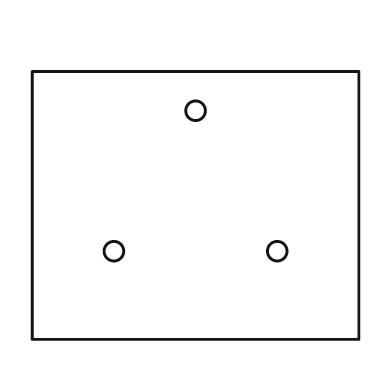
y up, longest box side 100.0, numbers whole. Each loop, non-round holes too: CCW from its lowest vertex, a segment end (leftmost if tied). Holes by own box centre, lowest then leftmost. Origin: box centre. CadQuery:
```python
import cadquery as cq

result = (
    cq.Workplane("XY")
    .moveTo(-50.0, -41.0)
    .lineTo(50.0, -41.0)
    .lineTo(50.0, 41.0)
    .lineTo(-50.0, 41.0)
    .close()
    .moveTo(-25.0, -14.0)
    .circle(3.0)
    .moveTo(25.0, -14.0)
    .circle(3.0)
    .moveTo(0.0, 29.0)
    .circle(3.0)
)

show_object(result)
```